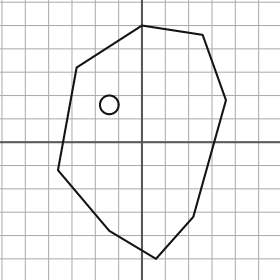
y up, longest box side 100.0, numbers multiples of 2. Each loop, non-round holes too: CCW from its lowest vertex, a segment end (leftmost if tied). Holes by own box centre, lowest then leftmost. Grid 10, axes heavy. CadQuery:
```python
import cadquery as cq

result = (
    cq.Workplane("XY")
    .moveTo(6.0, -50.0)
    .lineTo(22.0, -32.0)
    .lineTo(36.0, 18.0)
    .lineTo(26.0, 46.0)
    .lineTo(0.0, 50.0)
    .lineTo(-28.0, 32.0)
    .lineTo(-36.0, -12.0)
    .lineTo(-14.0, -38.0)
    .close()
    .moveTo(-14.0, 16.0)
    .circle(4.0)
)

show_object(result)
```